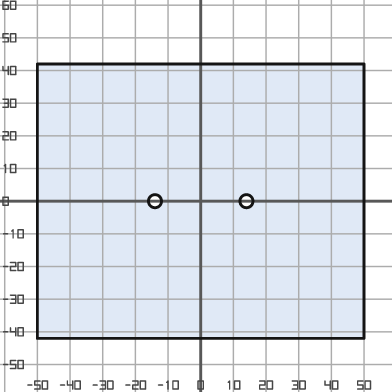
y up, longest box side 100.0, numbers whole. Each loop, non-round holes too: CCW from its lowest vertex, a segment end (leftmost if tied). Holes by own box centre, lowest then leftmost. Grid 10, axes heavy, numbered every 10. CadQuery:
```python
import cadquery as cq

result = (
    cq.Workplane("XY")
    .moveTo(-50.0, -42.0)
    .lineTo(50.0, -42.0)
    .lineTo(50.0, 42.0)
    .lineTo(-50.0, 42.0)
    .close()
    .moveTo(-14.0, 0.0)
    .circle(2.0)
    .moveTo(14.0, 0.0)
    .circle(2.0)
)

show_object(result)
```